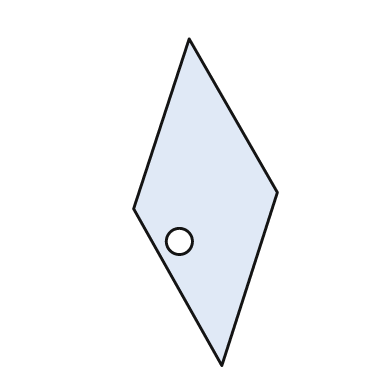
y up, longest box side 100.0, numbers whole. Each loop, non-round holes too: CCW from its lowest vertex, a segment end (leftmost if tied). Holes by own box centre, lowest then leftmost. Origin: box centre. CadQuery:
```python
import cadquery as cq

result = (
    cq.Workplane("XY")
    .moveTo(5.0, -50.0)
    .lineTo(22.0, 3.0)
    .lineTo(-5.0, 50.0)
    .lineTo(-22.0, -2.0)
    .close()
    .moveTo(-8.0, -12.0)
    .circle(4.0)
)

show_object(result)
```